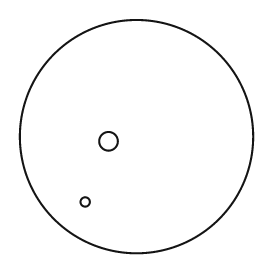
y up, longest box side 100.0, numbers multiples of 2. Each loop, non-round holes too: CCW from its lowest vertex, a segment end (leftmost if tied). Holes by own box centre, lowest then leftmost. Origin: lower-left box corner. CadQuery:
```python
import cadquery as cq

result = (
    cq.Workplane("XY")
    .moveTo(50.0, 50.0)
    .circle(50.0)
    .moveTo(28.0, 22.0)
    .circle(2.0)
    .moveTo(38.0, 48.0)
    .circle(4.0)
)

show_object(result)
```